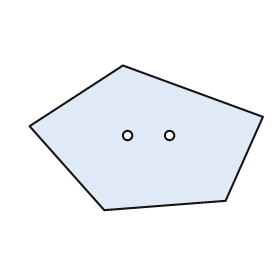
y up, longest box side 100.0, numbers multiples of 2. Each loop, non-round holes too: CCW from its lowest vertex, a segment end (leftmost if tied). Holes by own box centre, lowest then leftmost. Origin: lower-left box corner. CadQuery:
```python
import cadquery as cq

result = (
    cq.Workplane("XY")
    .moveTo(32.0, 0.0)
    .lineTo(84.0, 4.0)
    .lineTo(100.0, 40.0)
    .lineTo(40.0, 62.0)
    .lineTo(0.0, 36.0)
    .close()
    .moveTo(42.0, 32.0)
    .circle(2.0)
    .moveTo(60.0, 32.0)
    .circle(2.0)
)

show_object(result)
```